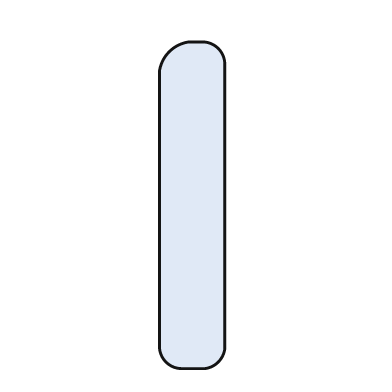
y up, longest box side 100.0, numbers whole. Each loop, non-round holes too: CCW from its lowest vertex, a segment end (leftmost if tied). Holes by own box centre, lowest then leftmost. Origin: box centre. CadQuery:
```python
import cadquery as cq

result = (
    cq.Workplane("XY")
    .moveTo(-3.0, -50.0)
    .lineTo(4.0, -50.0)
    .threePointArc((8.0, -48.0), (10.0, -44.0))
    .lineTo(10.0, 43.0)
    .threePointArc((8.0, 48.0), (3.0, 50.0))
    .lineTo(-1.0, 50.0)
    .threePointArc((-7.0, 47.0), (-10.0, 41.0))
    .lineTo(-10.0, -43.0)
    .threePointArc((-8.0, -48.0), (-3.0, -50.0))
    .close()
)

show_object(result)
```